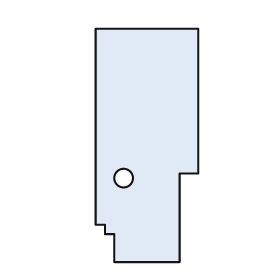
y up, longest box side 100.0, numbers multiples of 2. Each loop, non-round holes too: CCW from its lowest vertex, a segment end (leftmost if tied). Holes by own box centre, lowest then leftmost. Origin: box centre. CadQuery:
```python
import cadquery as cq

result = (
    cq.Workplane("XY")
    .moveTo(-14.0, -50.0)
    .lineTo(14.0, -50.0)
    .lineTo(14.0, -12.0)
    .lineTo(22.0, -12.0)
    .lineTo(22.0, 50.0)
    .lineTo(-22.0, 50.0)
    .lineTo(-22.0, -34.0)
    .lineTo(-18.0, -34.0)
    .lineTo(-18.0, -38.0)
    .lineTo(-14.0, -38.0)
    .close()
    .moveTo(-10.0, -14.0)
    .circle(4.0)
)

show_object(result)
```